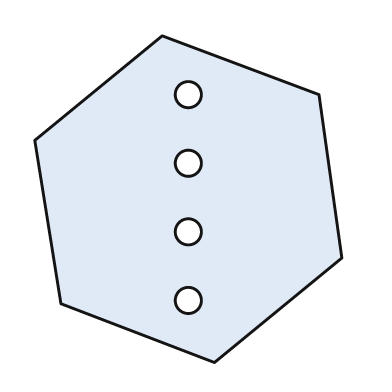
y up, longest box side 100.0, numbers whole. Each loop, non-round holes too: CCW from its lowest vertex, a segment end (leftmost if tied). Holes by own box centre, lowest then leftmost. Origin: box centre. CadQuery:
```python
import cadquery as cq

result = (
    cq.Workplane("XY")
    .moveTo(8.0, -50.0)
    .lineTo(47.0, -18.0)
    .lineTo(40.0, 32.0)
    .lineTo(-8.0, 50.0)
    .lineTo(-47.0, 18.0)
    .lineTo(-39.0, -32.0)
    .close()
    .moveTo(0.0, -31.0)
    .circle(4.0)
    .moveTo(0.0, -10.0)
    .circle(4.0)
    .moveTo(0.0, 11.0)
    .circle(4.0)
    .moveTo(0.0, 32.0)
    .circle(4.0)
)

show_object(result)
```